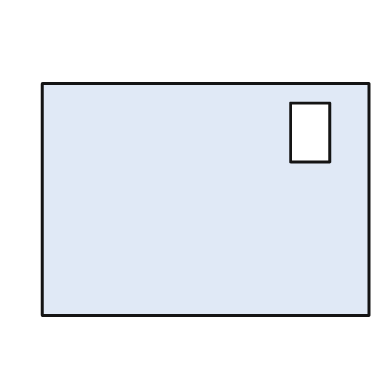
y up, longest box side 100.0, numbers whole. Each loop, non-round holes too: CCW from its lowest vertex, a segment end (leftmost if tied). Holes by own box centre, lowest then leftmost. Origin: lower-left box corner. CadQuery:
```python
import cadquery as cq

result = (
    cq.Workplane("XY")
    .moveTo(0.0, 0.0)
    .lineTo(100.0, 0.0)
    .lineTo(100.0, 71.0)
    .lineTo(0.0, 71.0)
    .close()
    .moveTo(76.0, 47.0)
    .lineTo(88.0, 47.0)
    .lineTo(88.0, 65.0)
    .lineTo(76.0, 65.0)
    .close()
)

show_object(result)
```